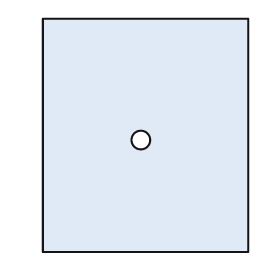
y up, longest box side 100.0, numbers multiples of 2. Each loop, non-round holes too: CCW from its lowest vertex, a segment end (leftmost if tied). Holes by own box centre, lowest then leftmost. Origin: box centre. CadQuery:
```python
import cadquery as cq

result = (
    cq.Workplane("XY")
    .moveTo(-44.0, -50.0)
    .lineTo(44.0, -50.0)
    .lineTo(44.0, 50.0)
    .lineTo(-44.0, 50.0)
    .close()
    .moveTo(-2.0, -2.0)
    .circle(4.0)
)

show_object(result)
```